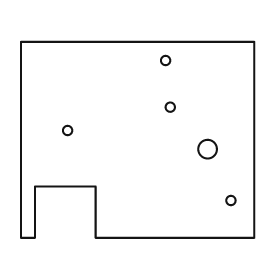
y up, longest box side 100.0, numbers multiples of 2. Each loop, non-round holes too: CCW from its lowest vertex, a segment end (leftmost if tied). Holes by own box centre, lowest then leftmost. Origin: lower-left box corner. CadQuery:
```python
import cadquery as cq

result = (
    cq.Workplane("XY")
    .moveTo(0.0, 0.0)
    .lineTo(6.0, 0.0)
    .lineTo(6.0, 22.0)
    .lineTo(32.0, 22.0)
    .lineTo(32.0, 0.0)
    .lineTo(100.0, 0.0)
    .lineTo(100.0, 84.0)
    .lineTo(0.0, 84.0)
    .close()
    .moveTo(90.0, 16.0)
    .circle(2.0)
    .moveTo(80.0, 38.0)
    .circle(4.0)
    .moveTo(20.0, 46.0)
    .circle(2.0)
    .moveTo(64.0, 56.0)
    .circle(2.0)
    .moveTo(62.0, 76.0)
    .circle(2.0)
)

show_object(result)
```